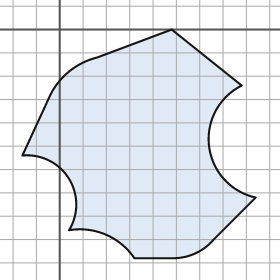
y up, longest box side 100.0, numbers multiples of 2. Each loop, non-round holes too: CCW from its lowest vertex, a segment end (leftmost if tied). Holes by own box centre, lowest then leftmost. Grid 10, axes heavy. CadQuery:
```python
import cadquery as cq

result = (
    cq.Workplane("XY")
    .moveTo(32.0, -98.0)
    .lineTo(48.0, -98.0)
    .threePointArc((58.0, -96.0), (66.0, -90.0))
    .lineTo(84.0, -72.0)
    .threePointArc((64.0, -50.0), (78.0, -24.0))
    .lineTo(48.0, 0.0)
    .lineTo(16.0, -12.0)
    .threePointArc((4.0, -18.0), (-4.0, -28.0))
    .lineTo(-16.0, -54.0)
    .threePointArc((4.0, -64.0), (4.0, -86.0))
    .threePointArc((20.0, -88.0), (32.0, -98.0))
    .close()
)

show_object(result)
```